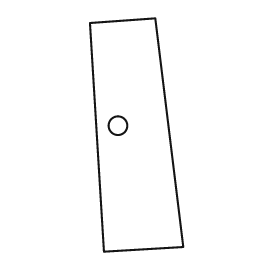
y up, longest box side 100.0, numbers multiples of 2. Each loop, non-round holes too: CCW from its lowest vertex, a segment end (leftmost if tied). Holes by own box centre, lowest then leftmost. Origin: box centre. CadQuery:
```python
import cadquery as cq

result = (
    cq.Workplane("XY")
    .moveTo(-14.0, -50.0)
    .lineTo(20.0, -48.0)
    .lineTo(8.0, 50.0)
    .lineTo(-20.0, 48.0)
    .close()
    .moveTo(-8.0, 4.0)
    .circle(4.0)
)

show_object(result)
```